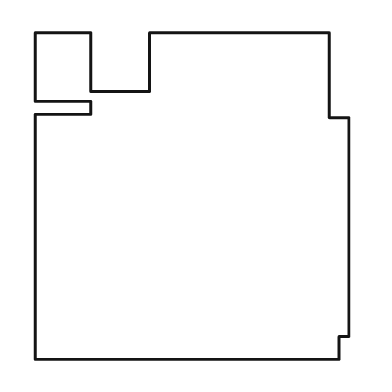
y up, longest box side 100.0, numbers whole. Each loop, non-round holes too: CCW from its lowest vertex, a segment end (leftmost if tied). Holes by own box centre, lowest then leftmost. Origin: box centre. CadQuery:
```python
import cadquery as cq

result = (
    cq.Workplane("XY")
    .moveTo(-48.0, -50.0)
    .lineTo(45.0, -50.0)
    .lineTo(45.0, -43.0)
    .lineTo(48.0, -43.0)
    .lineTo(48.0, 24.0)
    .lineTo(42.0, 24.0)
    .lineTo(42.0, 50.0)
    .lineTo(-13.0, 50.0)
    .lineTo(-13.0, 32.0)
    .lineTo(-31.0, 32.0)
    .lineTo(-31.0, 50.0)
    .lineTo(-48.0, 50.0)
    .lineTo(-48.0, 29.0)
    .lineTo(-31.0, 29.0)
    .lineTo(-31.0, 25.0)
    .lineTo(-48.0, 25.0)
    .close()
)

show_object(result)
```